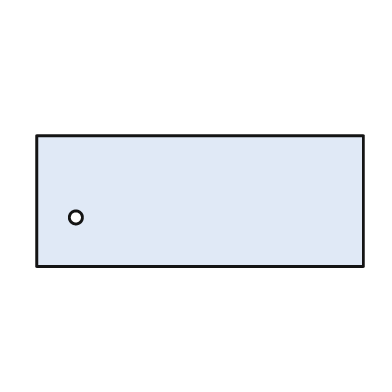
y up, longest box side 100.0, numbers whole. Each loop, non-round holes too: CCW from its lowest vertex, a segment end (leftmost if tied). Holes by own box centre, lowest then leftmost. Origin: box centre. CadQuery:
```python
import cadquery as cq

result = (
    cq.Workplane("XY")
    .moveTo(-50.0, -20.0)
    .lineTo(50.0, -20.0)
    .lineTo(50.0, 20.0)
    .lineTo(-50.0, 20.0)
    .close()
    .moveTo(-38.0, -5.0)
    .circle(2.0)
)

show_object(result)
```